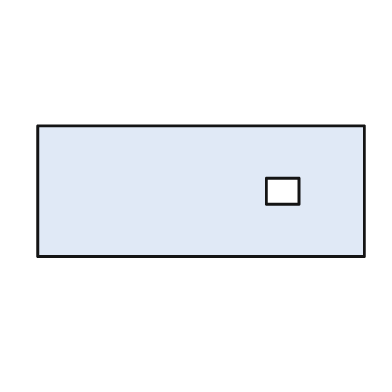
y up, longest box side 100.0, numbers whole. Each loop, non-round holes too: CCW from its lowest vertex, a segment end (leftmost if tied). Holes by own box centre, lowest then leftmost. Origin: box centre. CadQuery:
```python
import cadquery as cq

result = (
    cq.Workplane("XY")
    .moveTo(-50.0, -20.0)
    .lineTo(50.0, -20.0)
    .lineTo(50.0, 20.0)
    .lineTo(-50.0, 20.0)
    .close()
    .moveTo(20.0, -4.0)
    .lineTo(30.0, -4.0)
    .lineTo(30.0, 4.0)
    .lineTo(20.0, 4.0)
    .close()
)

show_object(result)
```